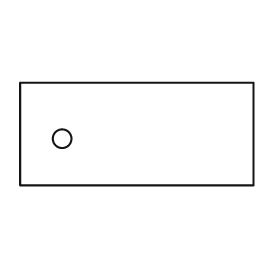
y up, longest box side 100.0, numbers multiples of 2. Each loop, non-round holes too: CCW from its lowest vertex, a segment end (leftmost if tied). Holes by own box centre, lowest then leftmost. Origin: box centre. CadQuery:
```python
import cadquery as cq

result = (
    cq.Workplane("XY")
    .moveTo(-50.0, -22.0)
    .lineTo(50.0, -22.0)
    .lineTo(50.0, 22.0)
    .lineTo(-50.0, 22.0)
    .close()
    .moveTo(-32.0, -2.0)
    .circle(4.0)
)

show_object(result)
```